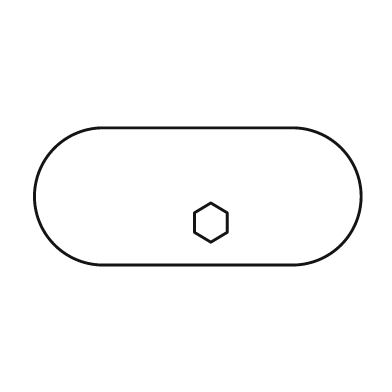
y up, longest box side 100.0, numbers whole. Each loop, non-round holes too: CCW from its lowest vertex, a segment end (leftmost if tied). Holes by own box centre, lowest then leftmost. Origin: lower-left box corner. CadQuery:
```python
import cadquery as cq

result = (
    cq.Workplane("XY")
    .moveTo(21.0, 0.0)
    .lineTo(79.0, 0.0)
    .threePointArc((100.0, 21.0), (79.0, 42.0))
    .lineTo(21.0, 42.0)
    .threePointArc((0.0, 21.0), (21.0, 0.0))
    .close()
    .moveTo(54.0, 7.0)
    .lineTo(59.0, 10.0)
    .lineTo(59.0, 16.0)
    .lineTo(54.0, 19.0)
    .lineTo(49.0, 16.0)
    .lineTo(49.0, 10.0)
    .close()
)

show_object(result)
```